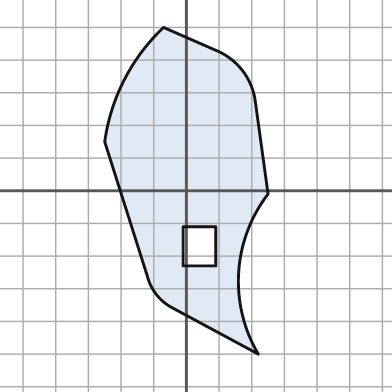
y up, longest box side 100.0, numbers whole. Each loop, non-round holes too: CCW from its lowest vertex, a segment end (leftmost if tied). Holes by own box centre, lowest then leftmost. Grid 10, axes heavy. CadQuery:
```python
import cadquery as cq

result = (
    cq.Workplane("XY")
    .moveTo(22.0, -50.0)
    .threePointArc((16.0, -25.0), (25.0, -1.0))
    .lineTo(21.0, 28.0)
    .threePointArc((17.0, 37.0), (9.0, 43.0))
    .lineTo(-7.0, 50.0)
    .threePointArc((-19.0, 34.0), (-25.0, 15.0))
    .lineTo(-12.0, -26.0)
    .threePointArc((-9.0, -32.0), (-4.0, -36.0))
    .close()
    .moveTo(-1.0, -23.0)
    .lineTo(9.0, -23.0)
    .lineTo(9.0, -11.0)
    .lineTo(-1.0, -11.0)
    .close()
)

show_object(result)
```